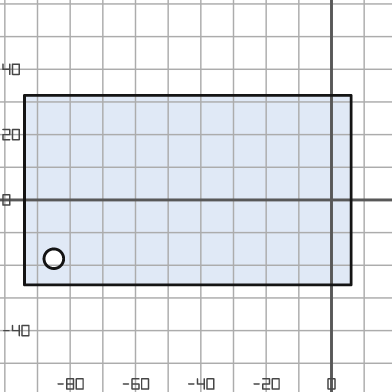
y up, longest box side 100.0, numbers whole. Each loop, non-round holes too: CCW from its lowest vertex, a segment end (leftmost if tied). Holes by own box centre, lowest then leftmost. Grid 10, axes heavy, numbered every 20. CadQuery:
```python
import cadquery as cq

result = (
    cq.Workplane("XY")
    .moveTo(-94.0, -26.0)
    .lineTo(6.0, -26.0)
    .lineTo(6.0, 32.0)
    .lineTo(-94.0, 32.0)
    .close()
    .moveTo(-85.0, -18.0)
    .circle(3.0)
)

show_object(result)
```